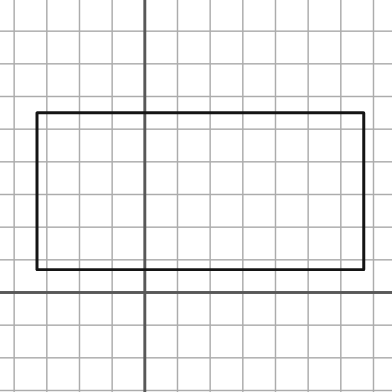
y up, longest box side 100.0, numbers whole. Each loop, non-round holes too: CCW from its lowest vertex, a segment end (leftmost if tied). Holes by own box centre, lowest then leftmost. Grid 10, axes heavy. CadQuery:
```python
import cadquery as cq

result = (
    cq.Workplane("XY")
    .moveTo(-33.0, 7.0)
    .lineTo(67.0, 7.0)
    .lineTo(67.0, 55.0)
    .lineTo(-33.0, 55.0)
    .close()
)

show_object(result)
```